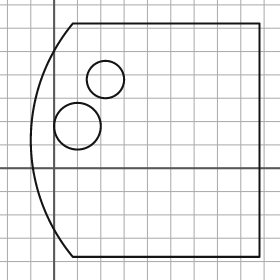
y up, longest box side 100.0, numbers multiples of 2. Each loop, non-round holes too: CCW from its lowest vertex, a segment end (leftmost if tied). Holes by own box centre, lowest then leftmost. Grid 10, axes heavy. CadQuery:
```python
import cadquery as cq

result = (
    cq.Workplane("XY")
    .moveTo(8.0, -38.0)
    .lineTo(88.0, -38.0)
    .lineTo(88.0, 62.0)
    .lineTo(8.0, 62.0)
    .threePointArc((-10.0, 12.0), (8.0, -38.0))
    .close()
    .moveTo(10.0, 18.0)
    .circle(10.0)
    .moveTo(22.0, 38.0)
    .circle(8.0)
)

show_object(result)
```